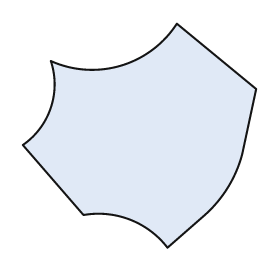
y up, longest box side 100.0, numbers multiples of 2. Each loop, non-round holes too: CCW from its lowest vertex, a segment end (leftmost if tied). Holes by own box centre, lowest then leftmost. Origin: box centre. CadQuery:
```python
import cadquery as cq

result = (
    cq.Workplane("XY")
    .moveTo(12.0, -48.0)
    .lineTo(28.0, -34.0)
    .threePointArc((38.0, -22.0), (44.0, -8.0))
    .lineTo(50.0, 20.0)
    .lineTo(16.0, 48.0)
    .threePointArc((-8.0, 30.0), (-38.0, 32.0))
    .threePointArc((-38.0, 12.0), (-50.0, -4.0))
    .lineTo(-24.0, -34.0)
    .threePointArc((-4.0, -36.0), (12.0, -48.0))
    .close()
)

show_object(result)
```